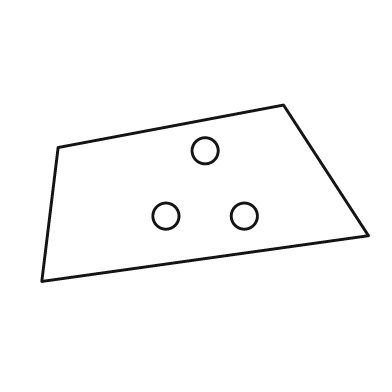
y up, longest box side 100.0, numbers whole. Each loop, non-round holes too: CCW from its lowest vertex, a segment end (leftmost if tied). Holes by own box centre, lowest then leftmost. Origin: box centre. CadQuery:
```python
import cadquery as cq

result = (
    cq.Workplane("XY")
    .moveTo(-50.0, -27.0)
    .lineTo(50.0, -13.0)
    .lineTo(24.0, 27.0)
    .lineTo(-45.0, 14.0)
    .close()
    .moveTo(-12.0, -7.0)
    .circle(4.0)
    .moveTo(12.0, -7.0)
    .circle(4.0)
    .moveTo(0.0, 13.0)
    .circle(4.0)
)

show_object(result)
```